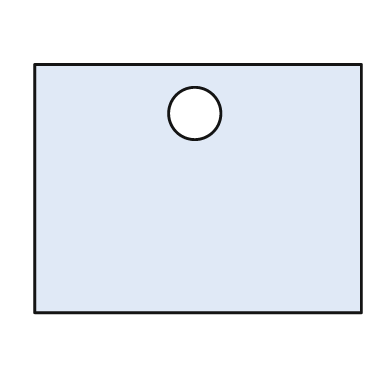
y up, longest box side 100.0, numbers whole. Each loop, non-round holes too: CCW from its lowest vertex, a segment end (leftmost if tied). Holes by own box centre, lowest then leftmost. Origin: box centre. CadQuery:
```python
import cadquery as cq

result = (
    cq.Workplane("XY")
    .moveTo(-50.0, -38.0)
    .lineTo(50.0, -38.0)
    .lineTo(50.0, 38.0)
    .lineTo(-50.0, 38.0)
    .close()
    .moveTo(-1.0, 23.0)
    .circle(8.0)
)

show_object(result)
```